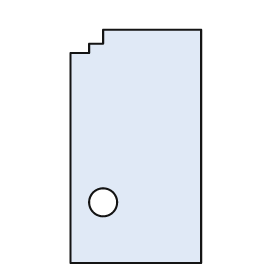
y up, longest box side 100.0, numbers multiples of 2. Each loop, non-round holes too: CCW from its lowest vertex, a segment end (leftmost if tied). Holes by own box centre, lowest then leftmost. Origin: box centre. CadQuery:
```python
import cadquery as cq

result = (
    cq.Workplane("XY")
    .moveTo(-28.0, -50.0)
    .lineTo(28.0, -50.0)
    .lineTo(28.0, 50.0)
    .lineTo(-14.0, 50.0)
    .lineTo(-14.0, 44.0)
    .lineTo(-20.0, 44.0)
    .lineTo(-20.0, 40.0)
    .lineTo(-28.0, 40.0)
    .close()
    .moveTo(-14.0, -24.0)
    .circle(6.0)
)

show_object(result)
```